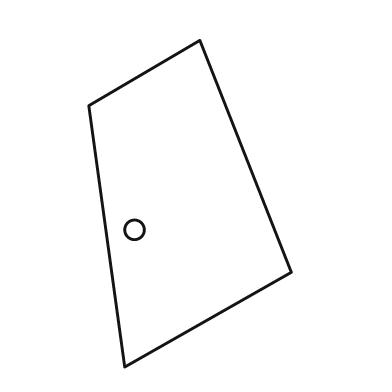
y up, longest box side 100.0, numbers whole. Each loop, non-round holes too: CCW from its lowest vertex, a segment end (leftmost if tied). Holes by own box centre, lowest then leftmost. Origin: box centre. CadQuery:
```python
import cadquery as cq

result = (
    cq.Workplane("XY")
    .moveTo(-20.0, -50.0)
    .lineTo(31.0, -21.0)
    .lineTo(3.0, 50.0)
    .lineTo(-31.0, 30.0)
    .close()
    .moveTo(-17.0, -8.0)
    .circle(3.0)
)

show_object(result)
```